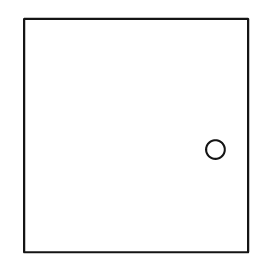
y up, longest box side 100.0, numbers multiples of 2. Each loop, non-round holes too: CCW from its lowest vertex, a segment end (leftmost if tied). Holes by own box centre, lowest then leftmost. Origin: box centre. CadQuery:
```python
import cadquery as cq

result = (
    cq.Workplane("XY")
    .moveTo(-48.0, -50.0)
    .lineTo(48.0, -50.0)
    .lineTo(48.0, 50.0)
    .lineTo(-48.0, 50.0)
    .close()
    .moveTo(34.0, -6.0)
    .circle(4.0)
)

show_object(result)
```